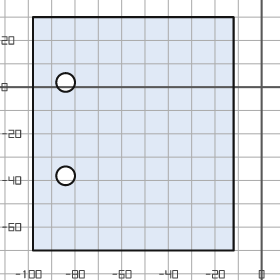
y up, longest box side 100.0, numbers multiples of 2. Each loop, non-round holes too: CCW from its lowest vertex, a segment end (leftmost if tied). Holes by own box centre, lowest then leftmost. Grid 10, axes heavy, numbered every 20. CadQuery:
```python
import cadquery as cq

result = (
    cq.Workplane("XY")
    .moveTo(-98.0, -70.0)
    .lineTo(-12.0, -70.0)
    .lineTo(-12.0, 30.0)
    .lineTo(-98.0, 30.0)
    .close()
    .moveTo(-84.0, -38.0)
    .circle(4.0)
    .moveTo(-84.0, 2.0)
    .circle(4.0)
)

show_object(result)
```